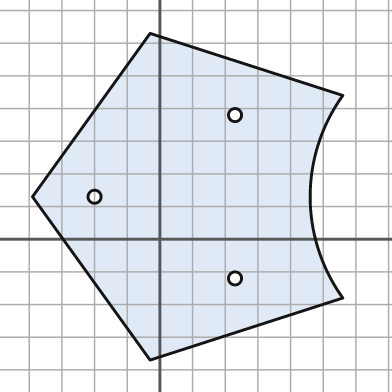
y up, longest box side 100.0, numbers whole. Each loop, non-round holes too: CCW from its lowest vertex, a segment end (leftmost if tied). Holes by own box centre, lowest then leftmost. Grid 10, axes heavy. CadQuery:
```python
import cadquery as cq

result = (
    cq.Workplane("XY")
    .moveTo(-3.0, -37.0)
    .lineTo(56.0, -18.0)
    .threePointArc((46.0, 13.0), (56.0, 44.0))
    .lineTo(-3.0, 63.0)
    .lineTo(-39.0, 13.0)
    .close()
    .moveTo(23.0, -12.0)
    .circle(2.0)
    .moveTo(-20.0, 13.0)
    .circle(2.0)
    .moveTo(23.0, 38.0)
    .circle(2.0)
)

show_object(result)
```